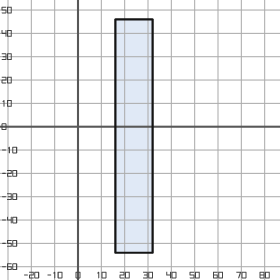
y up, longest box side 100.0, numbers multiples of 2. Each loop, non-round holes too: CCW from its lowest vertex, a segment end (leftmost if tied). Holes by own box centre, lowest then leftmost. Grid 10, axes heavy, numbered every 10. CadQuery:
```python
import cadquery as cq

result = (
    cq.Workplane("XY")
    .moveTo(16.0, -54.0)
    .lineTo(32.0, -54.0)
    .lineTo(32.0, 46.0)
    .lineTo(16.0, 46.0)
    .close()
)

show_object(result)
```